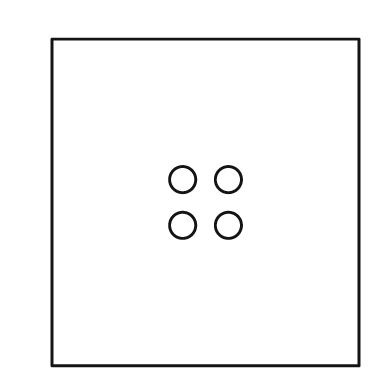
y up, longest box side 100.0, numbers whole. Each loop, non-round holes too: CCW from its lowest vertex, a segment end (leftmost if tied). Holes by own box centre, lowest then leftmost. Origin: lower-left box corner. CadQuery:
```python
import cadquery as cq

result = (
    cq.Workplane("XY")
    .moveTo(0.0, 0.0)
    .lineTo(94.0, 0.0)
    .lineTo(94.0, 100.0)
    .lineTo(0.0, 100.0)
    .close()
    .moveTo(40.0, 43.0)
    .circle(4.0)
    .moveTo(54.0, 43.0)
    .circle(4.0)
    .moveTo(40.0, 57.0)
    .circle(4.0)
    .moveTo(54.0, 57.0)
    .circle(4.0)
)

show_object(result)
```